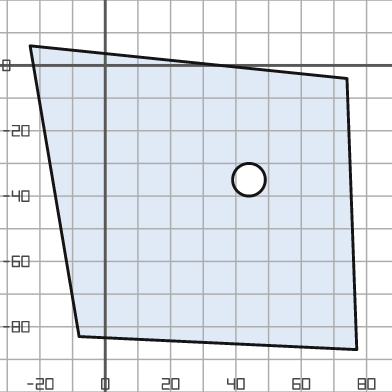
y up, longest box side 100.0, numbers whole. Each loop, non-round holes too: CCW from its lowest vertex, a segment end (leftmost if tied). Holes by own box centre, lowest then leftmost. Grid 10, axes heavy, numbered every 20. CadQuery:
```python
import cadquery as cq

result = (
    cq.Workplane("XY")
    .moveTo(77.0, -87.0)
    .lineTo(74.0, -4.0)
    .lineTo(-23.0, 6.0)
    .lineTo(-8.0, -83.0)
    .close()
    .moveTo(44.0, -35.0)
    .circle(5.0)
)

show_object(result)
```